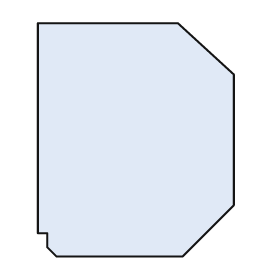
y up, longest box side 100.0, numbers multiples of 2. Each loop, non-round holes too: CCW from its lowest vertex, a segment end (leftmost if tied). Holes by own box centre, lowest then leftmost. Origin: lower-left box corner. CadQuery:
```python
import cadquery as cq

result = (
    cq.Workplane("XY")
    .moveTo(8.0, 0.0)
    .lineTo(62.0, 0.0)
    .lineTo(84.0, 22.0)
    .lineTo(84.0, 78.0)
    .lineTo(60.0, 100.0)
    .lineTo(0.0, 100.0)
    .lineTo(0.0, 10.0)
    .lineTo(4.0, 10.0)
    .lineTo(4.0, 4.0)
    .close()
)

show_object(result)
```